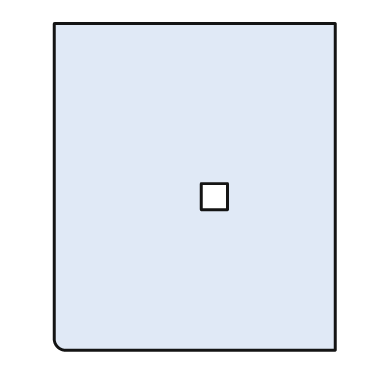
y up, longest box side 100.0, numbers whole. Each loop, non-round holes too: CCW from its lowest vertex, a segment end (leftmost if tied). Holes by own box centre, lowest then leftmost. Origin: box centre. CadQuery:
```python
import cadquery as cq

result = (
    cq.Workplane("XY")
    .moveTo(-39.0, -50.0)
    .lineTo(43.0, -50.0)
    .lineTo(43.0, 50.0)
    .lineTo(-43.0, 50.0)
    .lineTo(-43.0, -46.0)
    .threePointArc((-42.0, -49.0), (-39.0, -50.0))
    .close()
    .moveTo(2.0, -7.0)
    .lineTo(10.0, -7.0)
    .lineTo(10.0, 1.0)
    .lineTo(2.0, 1.0)
    .close()
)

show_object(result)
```